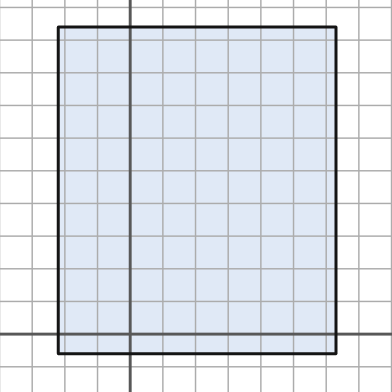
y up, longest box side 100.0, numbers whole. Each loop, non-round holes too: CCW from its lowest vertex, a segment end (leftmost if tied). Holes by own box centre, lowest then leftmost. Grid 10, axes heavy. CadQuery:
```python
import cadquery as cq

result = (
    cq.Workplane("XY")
    .moveTo(-22.0, -6.0)
    .lineTo(63.0, -6.0)
    .lineTo(63.0, 94.0)
    .lineTo(-22.0, 94.0)
    .close()
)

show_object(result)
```